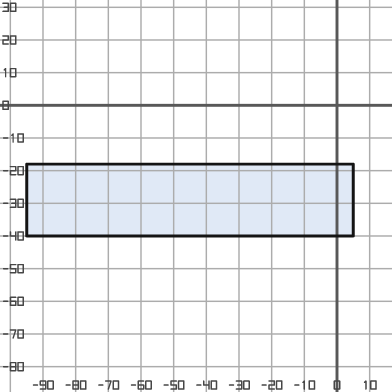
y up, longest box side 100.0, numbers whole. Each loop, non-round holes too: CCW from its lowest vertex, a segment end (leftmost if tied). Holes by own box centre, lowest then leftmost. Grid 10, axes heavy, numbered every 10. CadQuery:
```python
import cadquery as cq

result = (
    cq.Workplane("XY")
    .moveTo(-95.0, -40.0)
    .lineTo(5.0, -40.0)
    .lineTo(5.0, -18.0)
    .lineTo(-95.0, -18.0)
    .close()
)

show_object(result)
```